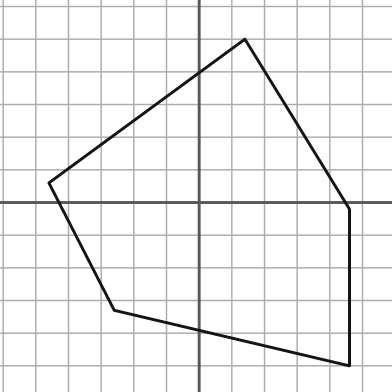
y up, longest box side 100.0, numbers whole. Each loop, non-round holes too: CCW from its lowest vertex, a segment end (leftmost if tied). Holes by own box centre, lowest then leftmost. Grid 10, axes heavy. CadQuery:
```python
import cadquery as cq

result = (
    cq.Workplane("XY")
    .moveTo(46.0, -50.0)
    .lineTo(46.0, -2.0)
    .lineTo(14.0, 50.0)
    .lineTo(-46.0, 6.0)
    .lineTo(-26.0, -33.0)
    .close()
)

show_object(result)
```